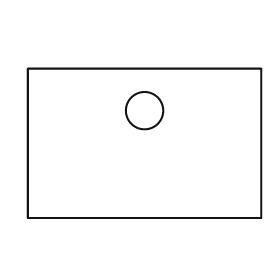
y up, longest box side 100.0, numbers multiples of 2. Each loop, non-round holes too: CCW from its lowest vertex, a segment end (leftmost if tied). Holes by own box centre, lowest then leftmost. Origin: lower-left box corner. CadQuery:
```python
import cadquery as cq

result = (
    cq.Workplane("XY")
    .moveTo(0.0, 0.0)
    .lineTo(100.0, 0.0)
    .lineTo(100.0, 64.0)
    .lineTo(0.0, 64.0)
    .close()
    .moveTo(50.0, 46.0)
    .circle(8.0)
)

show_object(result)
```